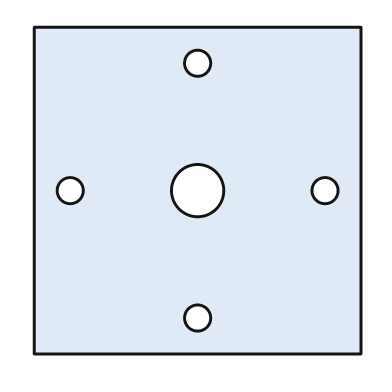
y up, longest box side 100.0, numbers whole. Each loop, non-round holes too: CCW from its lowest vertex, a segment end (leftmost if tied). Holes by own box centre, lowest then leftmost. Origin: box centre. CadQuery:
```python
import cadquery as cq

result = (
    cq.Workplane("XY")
    .moveTo(-50.0, -50.0)
    .lineTo(50.0, -50.0)
    .lineTo(50.0, 50.0)
    .lineTo(-50.0, 50.0)
    .close()
    .moveTo(0.0, -39.0)
    .circle(4.0)
    .moveTo(-39.0, 0.0)
    .circle(4.0)
    .moveTo(0.0, 0.0)
    .circle(8.0)
    .moveTo(39.0, 0.0)
    .circle(4.0)
    .moveTo(0.0, 39.0)
    .circle(4.0)
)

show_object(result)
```